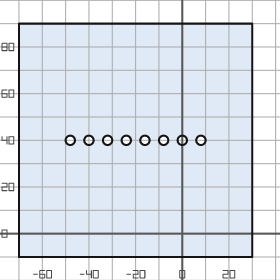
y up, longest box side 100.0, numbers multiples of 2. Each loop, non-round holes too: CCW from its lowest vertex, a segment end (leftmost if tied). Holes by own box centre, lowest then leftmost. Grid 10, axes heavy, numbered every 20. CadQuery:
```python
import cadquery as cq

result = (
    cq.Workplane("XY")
    .moveTo(-70.0, -10.0)
    .lineTo(30.0, -10.0)
    .lineTo(30.0, 90.0)
    .lineTo(-70.0, 90.0)
    .close()
    .moveTo(-48.0, 40.0)
    .circle(2.0)
    .moveTo(-40.0, 40.0)
    .circle(2.0)
    .moveTo(-32.0, 40.0)
    .circle(2.0)
    .moveTo(-24.0, 40.0)
    .circle(2.0)
    .moveTo(-16.0, 40.0)
    .circle(2.0)
    .moveTo(-8.0, 40.0)
    .circle(2.0)
    .moveTo(0.0, 40.0)
    .circle(2.0)
    .moveTo(8.0, 40.0)
    .circle(2.0)
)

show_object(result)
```